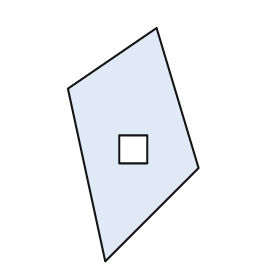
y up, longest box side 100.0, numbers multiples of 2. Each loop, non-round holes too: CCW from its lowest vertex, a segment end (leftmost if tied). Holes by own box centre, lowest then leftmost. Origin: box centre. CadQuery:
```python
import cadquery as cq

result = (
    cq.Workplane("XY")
    .moveTo(-12.0, -50.0)
    .lineTo(28.0, -10.0)
    .lineTo(10.0, 50.0)
    .lineTo(-28.0, 24.0)
    .close()
    .moveTo(-6.0, -8.0)
    .lineTo(6.0, -8.0)
    .lineTo(6.0, 4.0)
    .lineTo(-6.0, 4.0)
    .close()
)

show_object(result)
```